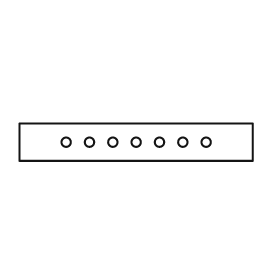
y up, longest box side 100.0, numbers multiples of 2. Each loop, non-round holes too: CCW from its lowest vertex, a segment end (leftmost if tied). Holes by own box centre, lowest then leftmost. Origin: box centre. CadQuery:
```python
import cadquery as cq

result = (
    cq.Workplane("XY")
    .moveTo(-50.0, -8.0)
    .lineTo(50.0, -8.0)
    .lineTo(50.0, 8.0)
    .lineTo(-50.0, 8.0)
    .close()
    .moveTo(-30.0, 0.0)
    .circle(2.0)
    .moveTo(-20.0, 0.0)
    .circle(2.0)
    .moveTo(-10.0, 0.0)
    .circle(2.0)
    .moveTo(0.0, 0.0)
    .circle(2.0)
    .moveTo(10.0, 0.0)
    .circle(2.0)
    .moveTo(20.0, 0.0)
    .circle(2.0)
    .moveTo(30.0, 0.0)
    .circle(2.0)
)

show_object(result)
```